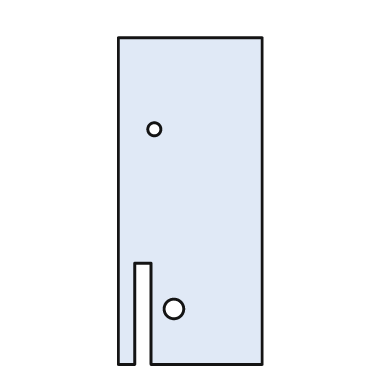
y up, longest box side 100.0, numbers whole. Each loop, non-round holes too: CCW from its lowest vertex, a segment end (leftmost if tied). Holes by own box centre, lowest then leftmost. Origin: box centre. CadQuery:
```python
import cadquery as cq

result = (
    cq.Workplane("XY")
    .moveTo(-22.0, -50.0)
    .lineTo(-17.0, -50.0)
    .lineTo(-17.0, -19.0)
    .lineTo(-12.0, -19.0)
    .lineTo(-12.0, -50.0)
    .lineTo(22.0, -50.0)
    .lineTo(22.0, 50.0)
    .lineTo(-22.0, 50.0)
    .close()
    .moveTo(-5.0, -33.0)
    .circle(3.0)
    .moveTo(-11.0, 22.0)
    .circle(2.0)
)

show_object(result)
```